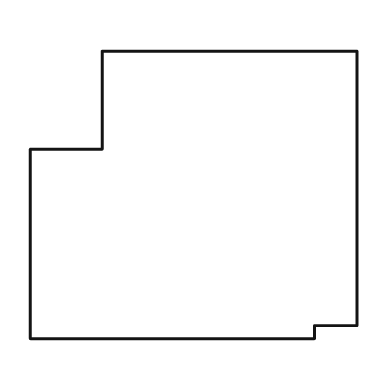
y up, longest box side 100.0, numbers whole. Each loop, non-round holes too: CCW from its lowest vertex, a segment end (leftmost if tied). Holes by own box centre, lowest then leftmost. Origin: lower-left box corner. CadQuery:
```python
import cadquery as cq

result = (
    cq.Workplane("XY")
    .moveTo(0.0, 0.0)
    .lineTo(87.0, 0.0)
    .lineTo(87.0, 4.0)
    .lineTo(100.0, 4.0)
    .lineTo(100.0, 88.0)
    .lineTo(22.0, 88.0)
    .lineTo(22.0, 58.0)
    .lineTo(0.0, 58.0)
    .close()
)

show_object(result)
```